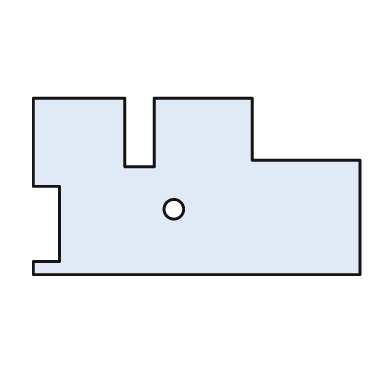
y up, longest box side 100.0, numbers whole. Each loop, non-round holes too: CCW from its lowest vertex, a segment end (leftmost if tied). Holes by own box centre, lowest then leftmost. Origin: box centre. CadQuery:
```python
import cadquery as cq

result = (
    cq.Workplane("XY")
    .moveTo(-50.0, -27.0)
    .lineTo(50.0, -27.0)
    .lineTo(50.0, 8.0)
    .lineTo(17.0, 8.0)
    .lineTo(17.0, 27.0)
    .lineTo(-13.0, 27.0)
    .lineTo(-13.0, 6.0)
    .lineTo(-22.0, 6.0)
    .lineTo(-22.0, 27.0)
    .lineTo(-50.0, 27.0)
    .lineTo(-50.0, 0.0)
    .lineTo(-42.0, 0.0)
    .lineTo(-42.0, -23.0)
    .lineTo(-50.0, -23.0)
    .close()
    .moveTo(-7.0, -7.0)
    .circle(3.0)
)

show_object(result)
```